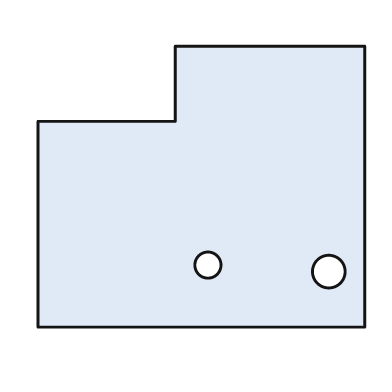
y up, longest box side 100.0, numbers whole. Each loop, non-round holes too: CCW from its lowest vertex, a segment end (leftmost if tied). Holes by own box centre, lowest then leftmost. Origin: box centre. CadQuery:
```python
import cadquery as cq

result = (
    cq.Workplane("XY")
    .moveTo(-50.0, -43.0)
    .lineTo(50.0, -43.0)
    .lineTo(50.0, 43.0)
    .lineTo(-8.0, 43.0)
    .lineTo(-8.0, 20.0)
    .lineTo(-50.0, 20.0)
    .close()
    .moveTo(39.0, -26.0)
    .circle(5.0)
    .moveTo(2.0, -24.0)
    .circle(4.0)
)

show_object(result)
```